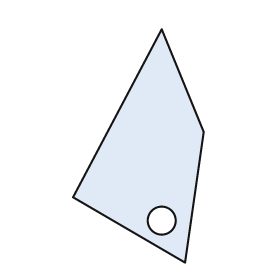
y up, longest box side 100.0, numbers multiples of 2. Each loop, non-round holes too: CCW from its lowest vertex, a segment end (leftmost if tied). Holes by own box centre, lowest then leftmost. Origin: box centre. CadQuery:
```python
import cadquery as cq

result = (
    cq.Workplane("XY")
    .moveTo(20.0, -50.0)
    .lineTo(28.0, 6.0)
    .lineTo(10.0, 50.0)
    .lineTo(-28.0, -22.0)
    .close()
    .moveTo(10.0, -32.0)
    .circle(6.0)
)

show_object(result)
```